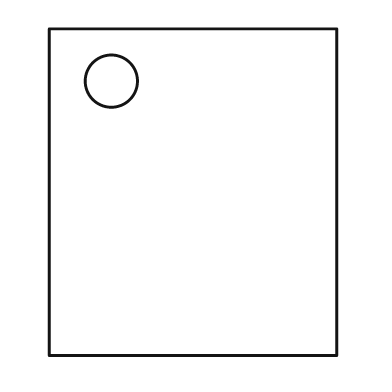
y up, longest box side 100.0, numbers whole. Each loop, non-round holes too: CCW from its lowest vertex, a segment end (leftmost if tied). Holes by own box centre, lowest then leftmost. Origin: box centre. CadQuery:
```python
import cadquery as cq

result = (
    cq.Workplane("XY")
    .moveTo(-44.0, -50.0)
    .lineTo(44.0, -50.0)
    .lineTo(44.0, 50.0)
    .lineTo(-44.0, 50.0)
    .close()
    .moveTo(-25.0, 34.0)
    .circle(8.0)
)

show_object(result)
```